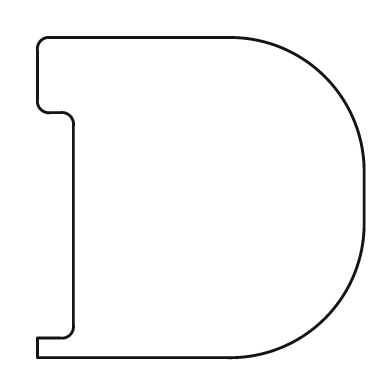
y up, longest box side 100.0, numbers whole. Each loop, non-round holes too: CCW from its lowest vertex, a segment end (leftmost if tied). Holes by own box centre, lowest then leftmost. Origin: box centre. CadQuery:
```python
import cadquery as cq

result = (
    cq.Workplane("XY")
    .moveTo(-50.0, -49.0)
    .lineTo(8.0, -49.0)
    .threePointArc((38.0, -37.0), (50.0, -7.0))
    .lineTo(50.0, 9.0)
    .threePointArc((38.0, 37.0), (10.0, 49.0))
    .lineTo(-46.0, 49.0)
    .threePointArc((-49.0, 48.0), (-50.0, 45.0))
    .lineTo(-50.0, 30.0)
    .threePointArc((-49.0, 27.0), (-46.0, 26.0))
    .lineTo(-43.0, 26.0)
    .threePointArc((-40.0, 25.0), (-39.0, 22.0))
    .lineTo(-39.0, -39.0)
    .threePointArc((-40.0, -42.0), (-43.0, -43.0))
    .lineTo(-50.0, -43.0)
    .close()
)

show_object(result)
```